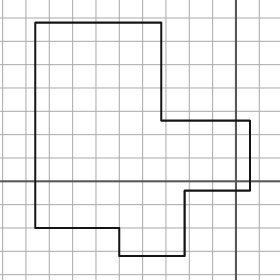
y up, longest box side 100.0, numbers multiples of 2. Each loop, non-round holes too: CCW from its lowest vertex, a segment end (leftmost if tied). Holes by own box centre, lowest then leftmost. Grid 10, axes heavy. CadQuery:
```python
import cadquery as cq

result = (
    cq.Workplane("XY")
    .moveTo(-50.0, -32.0)
    .lineTo(-22.0, -32.0)
    .lineTo(-22.0, -4.0)
    .lineTo(6.0, -4.0)
    .lineTo(6.0, 26.0)
    .lineTo(-32.0, 26.0)
    .lineTo(-32.0, 68.0)
    .lineTo(-86.0, 68.0)
    .lineTo(-86.0, -20.0)
    .lineTo(-50.0, -20.0)
    .close()
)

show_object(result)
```